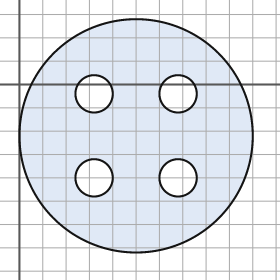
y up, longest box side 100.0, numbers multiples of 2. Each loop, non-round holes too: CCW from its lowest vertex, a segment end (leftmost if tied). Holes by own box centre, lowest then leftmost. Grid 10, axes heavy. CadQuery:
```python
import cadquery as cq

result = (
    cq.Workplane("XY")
    .moveTo(50.0, -22.0)
    .circle(50.0)
    .moveTo(32.0, -40.0)
    .circle(8.0)
    .moveTo(68.0, -40.0)
    .circle(8.0)
    .moveTo(32.0, -4.0)
    .circle(8.0)
    .moveTo(68.0, -4.0)
    .circle(8.0)
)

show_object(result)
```